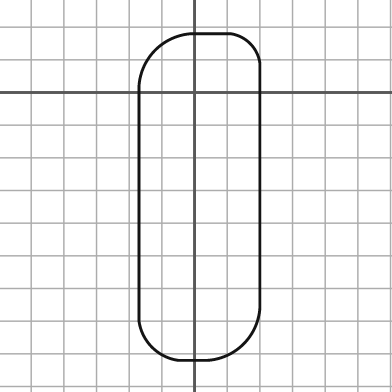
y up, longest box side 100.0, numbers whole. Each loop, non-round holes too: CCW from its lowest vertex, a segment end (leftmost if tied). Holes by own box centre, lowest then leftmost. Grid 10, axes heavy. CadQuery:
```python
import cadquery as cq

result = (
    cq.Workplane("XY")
    .moveTo(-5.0, -82.0)
    .lineTo(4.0, -82.0)
    .threePointArc((15.0, -77.0), (20.0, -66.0))
    .lineTo(20.0, 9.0)
    .threePointArc((17.0, 15.0), (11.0, 18.0))
    .lineTo(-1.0, 18.0)
    .threePointArc((-12.0, 13.0), (-17.0, 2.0))
    .lineTo(-17.0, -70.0)
    .threePointArc((-13.0, -78.0), (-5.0, -82.0))
    .close()
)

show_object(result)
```